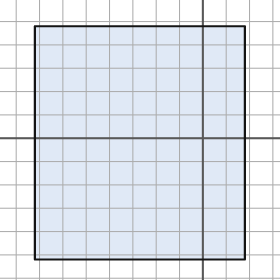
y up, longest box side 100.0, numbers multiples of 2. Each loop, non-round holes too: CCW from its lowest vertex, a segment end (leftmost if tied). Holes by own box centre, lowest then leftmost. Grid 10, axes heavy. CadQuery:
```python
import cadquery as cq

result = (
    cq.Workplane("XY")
    .moveTo(-72.0, -52.0)
    .lineTo(18.0, -52.0)
    .lineTo(18.0, 48.0)
    .lineTo(-72.0, 48.0)
    .close()
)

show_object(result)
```